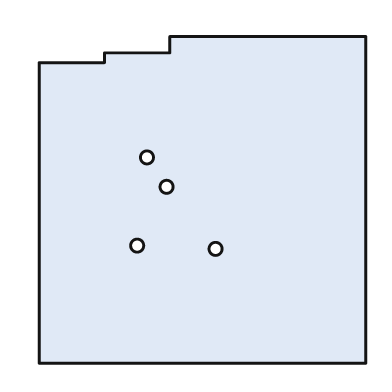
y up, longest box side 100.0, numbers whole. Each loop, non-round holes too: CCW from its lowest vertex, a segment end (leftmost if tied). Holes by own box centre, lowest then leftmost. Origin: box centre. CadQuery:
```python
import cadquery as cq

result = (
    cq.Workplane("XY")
    .moveTo(-50.0, -50.0)
    .lineTo(50.0, -50.0)
    .lineTo(50.0, 50.0)
    .lineTo(-10.0, 50.0)
    .lineTo(-10.0, 45.0)
    .lineTo(-30.0, 45.0)
    .lineTo(-30.0, 42.0)
    .lineTo(-50.0, 42.0)
    .close()
    .moveTo(4.0, -15.0)
    .circle(2.0)
    .moveTo(-20.0, -14.0)
    .circle(2.0)
    .moveTo(-11.0, 4.0)
    .circle(2.0)
    .moveTo(-17.0, 13.0)
    .circle(2.0)
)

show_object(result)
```